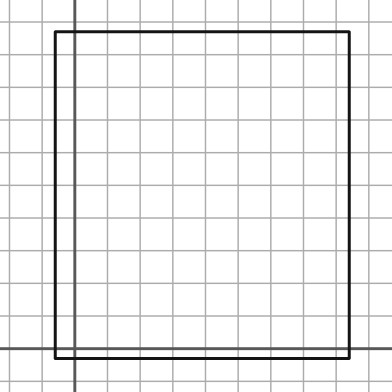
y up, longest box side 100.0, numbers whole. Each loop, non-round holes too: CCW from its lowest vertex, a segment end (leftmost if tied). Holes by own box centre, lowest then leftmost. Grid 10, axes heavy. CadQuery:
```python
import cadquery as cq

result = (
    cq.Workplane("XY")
    .moveTo(-6.0, -3.0)
    .lineTo(84.0, -3.0)
    .lineTo(84.0, 97.0)
    .lineTo(-6.0, 97.0)
    .close()
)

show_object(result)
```